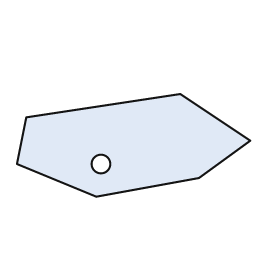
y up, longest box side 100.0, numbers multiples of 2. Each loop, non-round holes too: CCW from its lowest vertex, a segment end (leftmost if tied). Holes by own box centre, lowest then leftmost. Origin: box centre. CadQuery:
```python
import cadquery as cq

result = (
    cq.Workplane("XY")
    .moveTo(-16.0, -22.0)
    .lineTo(28.0, -14.0)
    .lineTo(50.0, 2.0)
    .lineTo(20.0, 22.0)
    .lineTo(-46.0, 12.0)
    .lineTo(-50.0, -8.0)
    .close()
    .moveTo(-14.0, -8.0)
    .circle(4.0)
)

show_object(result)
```